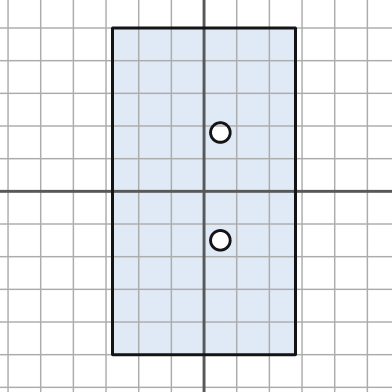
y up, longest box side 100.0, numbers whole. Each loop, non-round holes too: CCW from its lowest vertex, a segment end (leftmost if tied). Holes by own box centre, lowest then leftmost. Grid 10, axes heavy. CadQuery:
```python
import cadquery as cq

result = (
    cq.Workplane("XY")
    .moveTo(-28.0, -50.0)
    .lineTo(28.0, -50.0)
    .lineTo(28.0, 50.0)
    .lineTo(-28.0, 50.0)
    .close()
    .moveTo(5.0, -15.0)
    .circle(3.0)
    .moveTo(5.0, 18.0)
    .circle(3.0)
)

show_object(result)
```